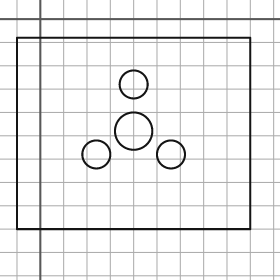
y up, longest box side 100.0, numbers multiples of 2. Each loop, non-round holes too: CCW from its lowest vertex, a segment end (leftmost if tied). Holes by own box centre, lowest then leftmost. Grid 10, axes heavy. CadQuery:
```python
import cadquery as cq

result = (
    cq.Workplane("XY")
    .moveTo(-10.0, -90.0)
    .lineTo(90.0, -90.0)
    .lineTo(90.0, -8.0)
    .lineTo(-10.0, -8.0)
    .close()
    .moveTo(24.0, -58.0)
    .circle(6.0)
    .moveTo(56.0, -58.0)
    .circle(6.0)
    .moveTo(40.0, -48.0)
    .circle(8.0)
    .moveTo(40.0, -28.0)
    .circle(6.0)
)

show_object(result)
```